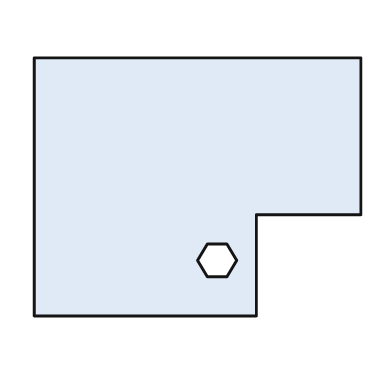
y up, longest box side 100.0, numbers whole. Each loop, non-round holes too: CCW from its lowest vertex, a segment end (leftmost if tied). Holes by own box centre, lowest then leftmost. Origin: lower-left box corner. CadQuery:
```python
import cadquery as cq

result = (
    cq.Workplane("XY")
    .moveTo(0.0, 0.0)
    .lineTo(68.0, 0.0)
    .lineTo(68.0, 31.0)
    .lineTo(100.0, 31.0)
    .lineTo(100.0, 79.0)
    .lineTo(0.0, 79.0)
    .close()
    .moveTo(53.0, 12.0)
    .lineTo(59.0, 12.0)
    .lineTo(62.0, 17.0)
    .lineTo(59.0, 22.0)
    .lineTo(53.0, 22.0)
    .lineTo(50.0, 17.0)
    .close()
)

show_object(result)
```